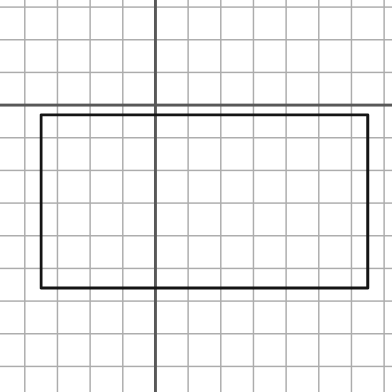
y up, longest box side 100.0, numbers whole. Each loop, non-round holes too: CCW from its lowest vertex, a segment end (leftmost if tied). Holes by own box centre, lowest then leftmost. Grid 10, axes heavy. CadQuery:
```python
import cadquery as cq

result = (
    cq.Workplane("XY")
    .moveTo(-35.0, -56.0)
    .lineTo(65.0, -56.0)
    .lineTo(65.0, -3.0)
    .lineTo(-35.0, -3.0)
    .close()
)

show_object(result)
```